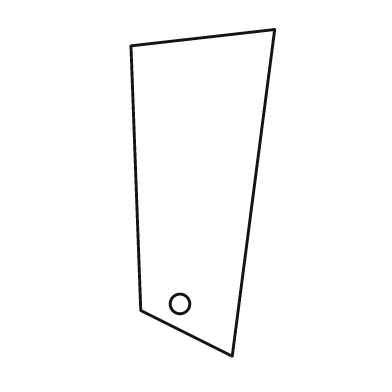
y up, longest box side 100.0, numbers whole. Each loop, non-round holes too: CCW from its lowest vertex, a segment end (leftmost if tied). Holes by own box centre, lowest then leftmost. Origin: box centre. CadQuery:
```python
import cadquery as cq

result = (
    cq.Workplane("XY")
    .moveTo(9.0, -50.0)
    .lineTo(22.0, 50.0)
    .lineTo(-22.0, 45.0)
    .lineTo(-19.0, -36.0)
    .close()
    .moveTo(-7.0, -34.0)
    .circle(3.0)
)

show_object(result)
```